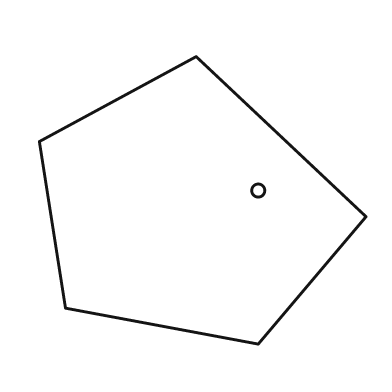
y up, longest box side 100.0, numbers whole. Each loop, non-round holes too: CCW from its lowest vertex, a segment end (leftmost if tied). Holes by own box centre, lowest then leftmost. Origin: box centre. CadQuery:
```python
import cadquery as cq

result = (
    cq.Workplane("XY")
    .moveTo(17.0, -44.0)
    .lineTo(50.0, -5.0)
    .lineTo(-2.0, 44.0)
    .lineTo(-50.0, 18.0)
    .lineTo(-42.0, -33.0)
    .close()
    .moveTo(17.0, 3.0)
    .circle(2.0)
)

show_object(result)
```